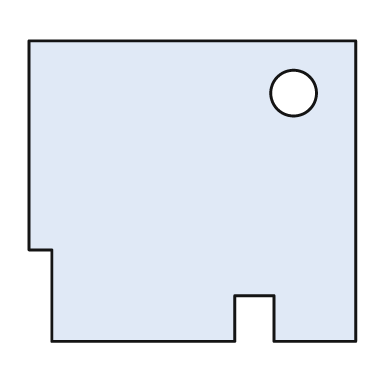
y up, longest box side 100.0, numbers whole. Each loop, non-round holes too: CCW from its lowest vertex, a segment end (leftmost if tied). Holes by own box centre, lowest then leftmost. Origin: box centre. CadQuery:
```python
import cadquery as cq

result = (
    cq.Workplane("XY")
    .moveTo(-43.0, -46.0)
    .lineTo(13.0, -46.0)
    .lineTo(13.0, -32.0)
    .lineTo(25.0, -32.0)
    .lineTo(25.0, -46.0)
    .lineTo(50.0, -46.0)
    .lineTo(50.0, 46.0)
    .lineTo(-50.0, 46.0)
    .lineTo(-50.0, -18.0)
    .lineTo(-43.0, -18.0)
    .close()
    .moveTo(31.0, 30.0)
    .circle(7.0)
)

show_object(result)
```